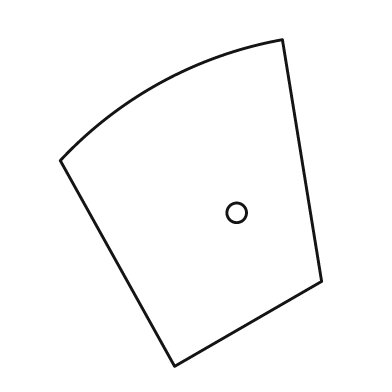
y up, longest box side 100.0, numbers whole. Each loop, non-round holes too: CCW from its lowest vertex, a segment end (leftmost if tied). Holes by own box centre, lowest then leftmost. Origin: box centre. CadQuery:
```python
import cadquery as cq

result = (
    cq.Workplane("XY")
    .moveTo(-5.0, -50.0)
    .lineTo(40.0, -24.0)
    .lineTo(28.0, 50.0)
    .threePointArc((-9.0, 37.0), (-40.0, 13.0))
    .close()
    .moveTo(14.0, -3.0)
    .circle(3.0)
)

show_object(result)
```